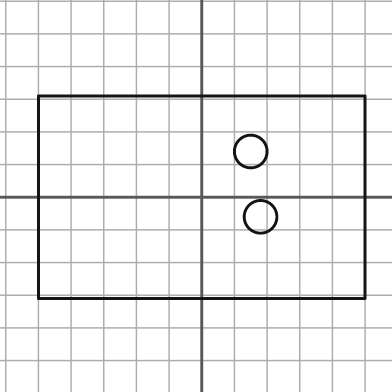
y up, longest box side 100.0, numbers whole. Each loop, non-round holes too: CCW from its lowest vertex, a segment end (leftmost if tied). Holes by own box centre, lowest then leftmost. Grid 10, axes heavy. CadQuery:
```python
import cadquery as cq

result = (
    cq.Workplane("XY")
    .moveTo(-50.0, -31.0)
    .lineTo(50.0, -31.0)
    .lineTo(50.0, 31.0)
    .lineTo(-50.0, 31.0)
    .close()
    .moveTo(18.0, -6.0)
    .circle(5.0)
    .moveTo(15.0, 14.0)
    .circle(5.0)
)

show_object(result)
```